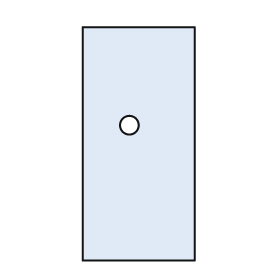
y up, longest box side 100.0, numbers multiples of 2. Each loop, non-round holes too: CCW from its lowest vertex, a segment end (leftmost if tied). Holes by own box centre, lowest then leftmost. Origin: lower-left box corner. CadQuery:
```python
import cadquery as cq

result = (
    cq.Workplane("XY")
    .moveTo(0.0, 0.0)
    .lineTo(48.0, 0.0)
    .lineTo(48.0, 100.0)
    .lineTo(0.0, 100.0)
    .close()
    .moveTo(20.0, 58.0)
    .circle(4.0)
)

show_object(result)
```